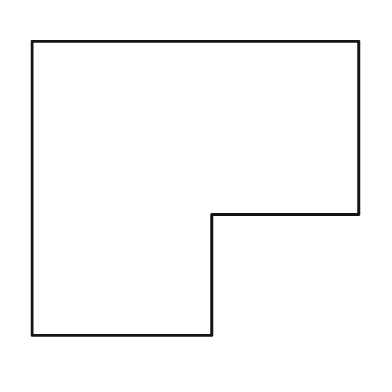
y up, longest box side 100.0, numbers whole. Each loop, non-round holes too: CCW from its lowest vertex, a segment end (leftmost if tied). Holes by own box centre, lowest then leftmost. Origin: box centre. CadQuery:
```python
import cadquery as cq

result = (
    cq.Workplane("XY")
    .moveTo(-50.0, -45.0)
    .lineTo(5.0, -45.0)
    .lineTo(5.0, -8.0)
    .lineTo(50.0, -8.0)
    .lineTo(50.0, 45.0)
    .lineTo(-50.0, 45.0)
    .close()
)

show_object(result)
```